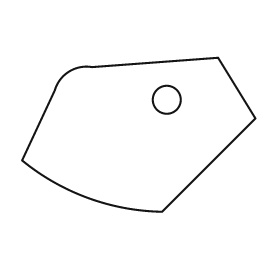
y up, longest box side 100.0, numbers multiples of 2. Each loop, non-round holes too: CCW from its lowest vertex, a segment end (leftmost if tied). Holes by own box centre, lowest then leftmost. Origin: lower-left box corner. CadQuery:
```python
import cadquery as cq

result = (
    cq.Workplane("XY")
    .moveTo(60.0, 0.0)
    .lineTo(100.0, 40.0)
    .lineTo(84.0, 66.0)
    .lineTo(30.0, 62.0)
    .threePointArc((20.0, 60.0), (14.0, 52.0))
    .lineTo(0.0, 22.0)
    .threePointArc((28.0, 6.0), (60.0, 0.0))
    .close()
    .moveTo(62.0, 48.0)
    .circle(6.0)
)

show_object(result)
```